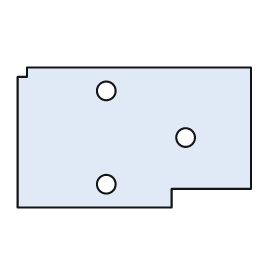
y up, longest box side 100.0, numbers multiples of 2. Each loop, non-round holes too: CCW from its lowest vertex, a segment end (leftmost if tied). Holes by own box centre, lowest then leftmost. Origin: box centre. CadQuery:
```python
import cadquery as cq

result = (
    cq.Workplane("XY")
    .moveTo(-50.0, -30.0)
    .lineTo(16.0, -30.0)
    .lineTo(16.0, -22.0)
    .lineTo(50.0, -22.0)
    .lineTo(50.0, 30.0)
    .lineTo(-46.0, 30.0)
    .lineTo(-46.0, 26.0)
    .lineTo(-50.0, 26.0)
    .close()
    .moveTo(-12.0, -20.0)
    .circle(4.0)
    .moveTo(22.0, 0.0)
    .circle(4.0)
    .moveTo(-12.0, 20.0)
    .circle(4.0)
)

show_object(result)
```